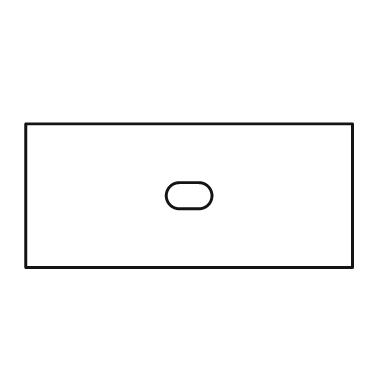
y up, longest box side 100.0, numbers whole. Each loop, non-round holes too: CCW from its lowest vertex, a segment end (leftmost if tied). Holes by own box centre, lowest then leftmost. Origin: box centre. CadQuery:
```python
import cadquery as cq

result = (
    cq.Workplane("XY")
    .moveTo(-50.0, -22.0)
    .lineTo(50.0, -22.0)
    .lineTo(50.0, 22.0)
    .lineTo(-50.0, 22.0)
    .close()
    .moveTo(-3.0, -4.0)
    .lineTo(3.0, -4.0)
    .threePointArc((7.0, 0.0), (3.0, 4.0))
    .lineTo(-3.0, 4.0)
    .threePointArc((-7.0, 0.0), (-3.0, -4.0))
    .close()
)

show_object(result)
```